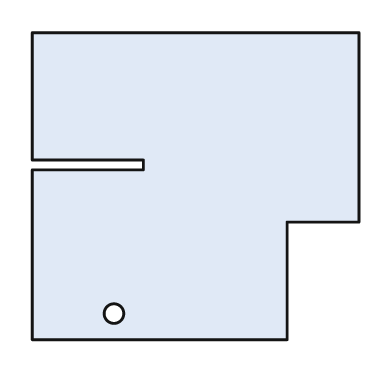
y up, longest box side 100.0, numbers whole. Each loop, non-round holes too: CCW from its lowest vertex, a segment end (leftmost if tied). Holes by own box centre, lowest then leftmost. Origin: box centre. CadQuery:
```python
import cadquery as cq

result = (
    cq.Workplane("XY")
    .moveTo(-50.0, -47.0)
    .lineTo(28.0, -47.0)
    .lineTo(28.0, -11.0)
    .lineTo(50.0, -11.0)
    .lineTo(50.0, 47.0)
    .lineTo(-50.0, 47.0)
    .lineTo(-50.0, 8.0)
    .lineTo(-16.0, 8.0)
    .lineTo(-16.0, 5.0)
    .lineTo(-50.0, 5.0)
    .close()
    .moveTo(-25.0, -39.0)
    .circle(3.0)
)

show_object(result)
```